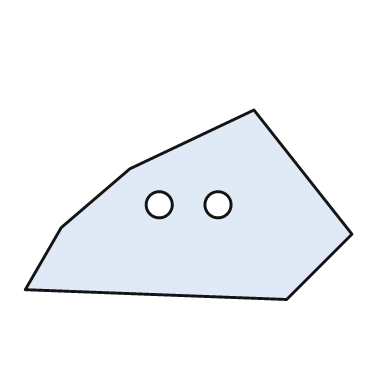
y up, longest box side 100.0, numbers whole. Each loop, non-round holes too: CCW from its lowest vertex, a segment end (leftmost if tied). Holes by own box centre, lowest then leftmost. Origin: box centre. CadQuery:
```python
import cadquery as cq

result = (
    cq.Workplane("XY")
    .moveTo(30.0, -29.0)
    .lineTo(50.0, -9.0)
    .lineTo(20.0, 29.0)
    .lineTo(-18.0, 11.0)
    .lineTo(-39.0, -7.0)
    .lineTo(-50.0, -26.0)
    .close()
    .moveTo(-9.0, 0.0)
    .circle(4.0)
    .moveTo(9.0, 0.0)
    .circle(4.0)
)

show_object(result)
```